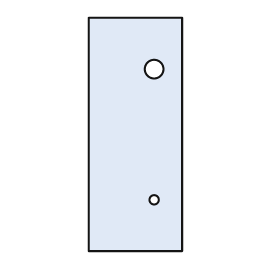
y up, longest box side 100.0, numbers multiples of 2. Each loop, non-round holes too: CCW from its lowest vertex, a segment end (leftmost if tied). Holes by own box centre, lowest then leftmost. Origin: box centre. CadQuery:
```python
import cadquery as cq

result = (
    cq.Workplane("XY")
    .moveTo(-20.0, -50.0)
    .lineTo(20.0, -50.0)
    .lineTo(20.0, 50.0)
    .lineTo(-20.0, 50.0)
    .close()
    .moveTo(8.0, -28.0)
    .circle(2.0)
    .moveTo(8.0, 28.0)
    .circle(4.0)
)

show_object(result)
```